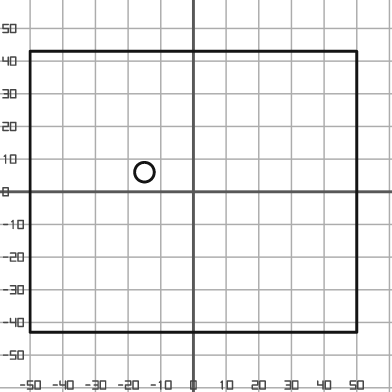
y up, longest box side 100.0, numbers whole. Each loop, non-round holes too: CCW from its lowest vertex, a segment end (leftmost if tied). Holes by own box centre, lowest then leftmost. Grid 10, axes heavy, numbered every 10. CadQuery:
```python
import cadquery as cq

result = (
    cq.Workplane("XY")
    .moveTo(-50.0, -43.0)
    .lineTo(50.0, -43.0)
    .lineTo(50.0, 43.0)
    .lineTo(-50.0, 43.0)
    .close()
    .moveTo(-15.0, 6.0)
    .circle(3.0)
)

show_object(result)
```